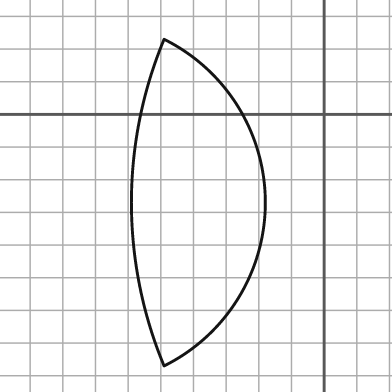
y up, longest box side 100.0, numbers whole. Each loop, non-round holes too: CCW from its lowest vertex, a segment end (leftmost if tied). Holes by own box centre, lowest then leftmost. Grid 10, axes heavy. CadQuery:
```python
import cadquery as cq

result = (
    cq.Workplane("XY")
    .moveTo(-49.0, -77.0)
    .threePointArc((-18.0, -27.0), (-49.0, 23.0))
    .threePointArc((-59.0, -27.0), (-49.0, -77.0))
    .close()
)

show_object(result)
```